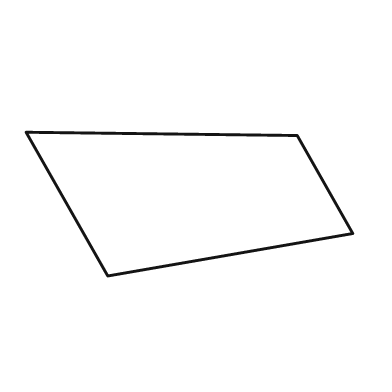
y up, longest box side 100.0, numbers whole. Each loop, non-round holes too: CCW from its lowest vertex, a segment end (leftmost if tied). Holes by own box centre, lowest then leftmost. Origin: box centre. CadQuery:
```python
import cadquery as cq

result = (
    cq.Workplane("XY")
    .moveTo(-25.0, -22.0)
    .lineTo(50.0, -9.0)
    .lineTo(33.0, 21.0)
    .lineTo(-50.0, 22.0)
    .close()
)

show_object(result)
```